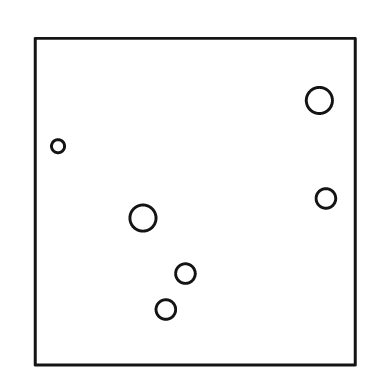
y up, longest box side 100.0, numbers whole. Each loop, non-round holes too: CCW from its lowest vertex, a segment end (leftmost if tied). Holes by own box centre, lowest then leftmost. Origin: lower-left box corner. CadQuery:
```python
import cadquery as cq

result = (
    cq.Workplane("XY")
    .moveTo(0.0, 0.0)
    .lineTo(98.0, 0.0)
    .lineTo(98.0, 100.0)
    .lineTo(0.0, 100.0)
    .close()
    .moveTo(40.0, 17.0)
    .circle(3.0)
    .moveTo(46.0, 28.0)
    .circle(3.0)
    .moveTo(33.0, 45.0)
    .circle(4.0)
    .moveTo(89.0, 51.0)
    .circle(3.0)
    .moveTo(7.0, 67.0)
    .circle(2.0)
    .moveTo(87.0, 81.0)
    .circle(4.0)
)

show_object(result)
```